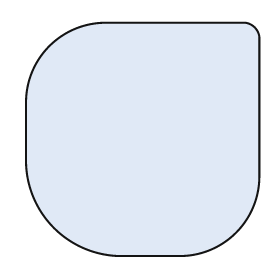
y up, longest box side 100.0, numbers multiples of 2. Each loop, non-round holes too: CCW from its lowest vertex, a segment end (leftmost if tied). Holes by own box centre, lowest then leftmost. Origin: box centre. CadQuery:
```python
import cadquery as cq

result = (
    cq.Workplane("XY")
    .moveTo(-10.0, -50.0)
    .lineTo(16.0, -50.0)
    .threePointArc((40.0, -40.0), (50.0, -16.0))
    .lineTo(50.0, 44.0)
    .threePointArc((48.0, 48.0), (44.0, 50.0))
    .lineTo(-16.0, 50.0)
    .threePointArc((-40.0, 40.0), (-50.0, 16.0))
    .lineTo(-50.0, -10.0)
    .threePointArc((-38.0, -38.0), (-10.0, -50.0))
    .close()
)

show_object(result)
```